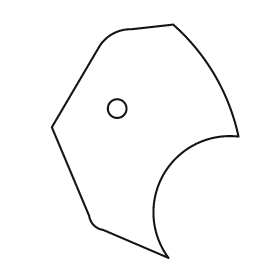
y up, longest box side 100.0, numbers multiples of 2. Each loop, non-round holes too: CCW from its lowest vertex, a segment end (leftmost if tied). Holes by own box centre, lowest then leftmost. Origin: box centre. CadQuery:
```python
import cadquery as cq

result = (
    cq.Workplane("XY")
    .moveTo(10.0, -50.0)
    .threePointArc((8.0, -14.0), (40.0, 2.0))
    .threePointArc((30.0, 28.0), (12.0, 50.0))
    .lineTo(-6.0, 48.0)
    .threePointArc((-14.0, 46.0), (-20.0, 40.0))
    .lineTo(-40.0, 6.0)
    .lineTo(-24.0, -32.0)
    .threePointArc((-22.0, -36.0), (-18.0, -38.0))
    .close()
    .moveTo(-12.0, 14.0)
    .circle(4.0)
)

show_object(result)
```